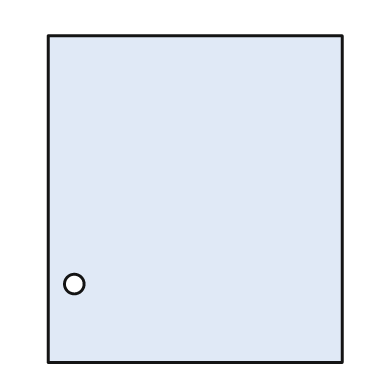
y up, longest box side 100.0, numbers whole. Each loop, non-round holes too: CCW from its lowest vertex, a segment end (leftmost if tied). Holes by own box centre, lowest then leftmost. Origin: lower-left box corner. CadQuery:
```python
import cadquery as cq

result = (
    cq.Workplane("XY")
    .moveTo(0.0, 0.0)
    .lineTo(90.0, 0.0)
    .lineTo(90.0, 100.0)
    .lineTo(0.0, 100.0)
    .close()
    .moveTo(8.0, 24.0)
    .circle(3.0)
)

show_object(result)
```